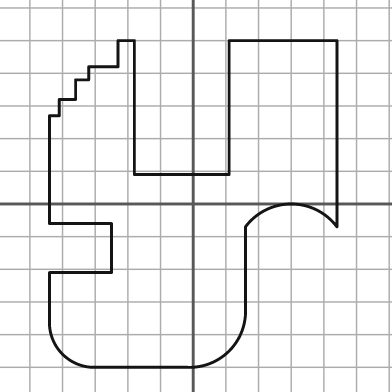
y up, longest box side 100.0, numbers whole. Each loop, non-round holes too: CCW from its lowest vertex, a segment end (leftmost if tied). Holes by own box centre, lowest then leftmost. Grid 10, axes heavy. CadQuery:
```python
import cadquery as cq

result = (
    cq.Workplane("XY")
    .moveTo(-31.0, -50.0)
    .lineTo(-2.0, -50.0)
    .threePointArc((11.0, -45.0), (16.0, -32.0))
    .lineTo(16.0, -7.0)
    .threePointArc((30.0, 0.0), (44.0, -7.0))
    .lineTo(44.0, 50.0)
    .lineTo(11.0, 50.0)
    .lineTo(11.0, 9.0)
    .lineTo(-18.0, 9.0)
    .lineTo(-18.0, 50.0)
    .lineTo(-23.0, 50.0)
    .lineTo(-23.0, 42.0)
    .lineTo(-32.0, 42.0)
    .lineTo(-32.0, 38.0)
    .lineTo(-36.0, 38.0)
    .lineTo(-36.0, 32.0)
    .lineTo(-41.0, 32.0)
    .lineTo(-41.0, 27.0)
    .lineTo(-44.0, 27.0)
    .lineTo(-44.0, -6.0)
    .lineTo(-25.0, -6.0)
    .lineTo(-25.0, -21.0)
    .lineTo(-44.0, -21.0)
    .lineTo(-44.0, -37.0)
    .threePointArc((-40.0, -46.0), (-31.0, -50.0))
    .close()
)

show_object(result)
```